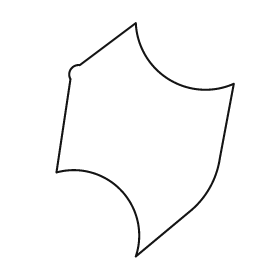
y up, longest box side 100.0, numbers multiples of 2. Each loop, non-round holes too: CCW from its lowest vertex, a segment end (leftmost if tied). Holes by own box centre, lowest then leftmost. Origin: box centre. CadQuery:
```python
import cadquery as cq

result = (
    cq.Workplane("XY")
    .moveTo(-4.0, -50.0)
    .lineTo(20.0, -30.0)
    .threePointArc((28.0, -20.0), (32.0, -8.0))
    .lineTo(38.0, 24.0)
    .threePointArc((10.0, 26.0), (-4.0, 50.0))
    .lineTo(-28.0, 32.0)
    .threePointArc((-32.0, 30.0), (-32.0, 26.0))
    .lineTo(-38.0, -14.0)
    .threePointArc((-10.0, -22.0), (-4.0, -50.0))
    .close()
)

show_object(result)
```